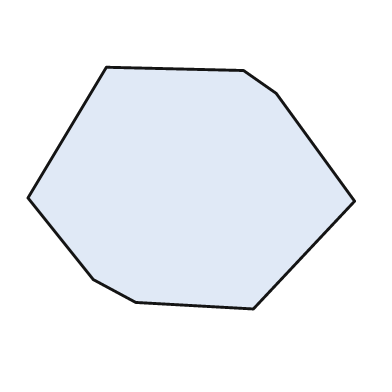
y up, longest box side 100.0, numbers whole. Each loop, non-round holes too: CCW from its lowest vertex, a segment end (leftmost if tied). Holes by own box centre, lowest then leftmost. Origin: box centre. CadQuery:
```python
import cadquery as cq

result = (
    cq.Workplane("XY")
    .moveTo(19.0, -37.0)
    .lineTo(50.0, -4.0)
    .lineTo(26.0, 29.0)
    .lineTo(16.0, 36.0)
    .lineTo(-26.0, 37.0)
    .lineTo(-50.0, -3.0)
    .lineTo(-30.0, -28.0)
    .lineTo(-17.0, -35.0)
    .close()
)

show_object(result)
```